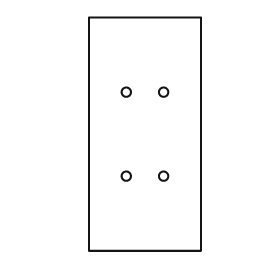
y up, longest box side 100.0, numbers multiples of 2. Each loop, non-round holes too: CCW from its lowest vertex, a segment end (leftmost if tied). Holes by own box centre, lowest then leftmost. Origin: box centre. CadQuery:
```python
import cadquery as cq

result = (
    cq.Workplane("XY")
    .moveTo(-24.0, -50.0)
    .lineTo(24.0, -50.0)
    .lineTo(24.0, 50.0)
    .lineTo(-24.0, 50.0)
    .close()
    .moveTo(-8.0, -18.0)
    .circle(2.0)
    .moveTo(8.0, -18.0)
    .circle(2.0)
    .moveTo(-8.0, 18.0)
    .circle(2.0)
    .moveTo(8.0, 18.0)
    .circle(2.0)
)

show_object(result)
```